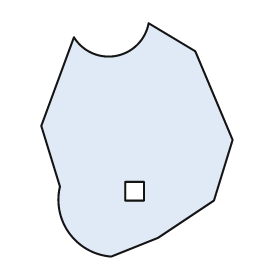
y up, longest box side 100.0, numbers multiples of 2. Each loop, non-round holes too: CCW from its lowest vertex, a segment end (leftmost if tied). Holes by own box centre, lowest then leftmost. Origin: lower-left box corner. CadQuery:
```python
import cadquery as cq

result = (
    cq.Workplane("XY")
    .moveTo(30.0, 0.0)
    .lineTo(50.0, 8.0)
    .lineTo(74.0, 24.0)
    .lineTo(82.0, 50.0)
    .lineTo(66.0, 88.0)
    .lineTo(46.0, 100.0)
    .threePointArc((32.0, 86.0), (14.0, 94.0))
    .lineTo(0.0, 56.0)
    .lineTo(8.0, 30.0)
    .threePointArc((12.0, 10.0), (30.0, 0.0))
    .close()
    .moveTo(36.0, 24.0)
    .lineTo(44.0, 24.0)
    .lineTo(44.0, 32.0)
    .lineTo(36.0, 32.0)
    .close()
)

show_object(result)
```